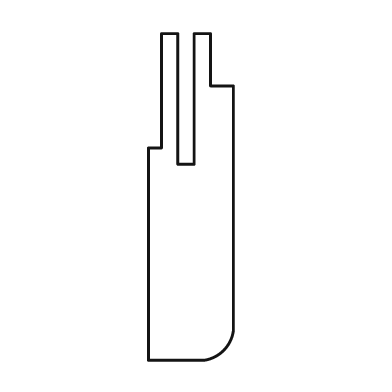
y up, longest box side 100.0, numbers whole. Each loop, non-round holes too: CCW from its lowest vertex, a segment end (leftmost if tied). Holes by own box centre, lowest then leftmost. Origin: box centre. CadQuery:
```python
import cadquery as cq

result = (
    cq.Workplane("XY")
    .moveTo(-13.0, -50.0)
    .lineTo(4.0, -50.0)
    .threePointArc((10.0, -47.0), (13.0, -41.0))
    .lineTo(13.0, 34.0)
    .lineTo(6.0, 34.0)
    .lineTo(6.0, 50.0)
    .lineTo(1.0, 50.0)
    .lineTo(1.0, 10.0)
    .lineTo(-4.0, 10.0)
    .lineTo(-4.0, 50.0)
    .lineTo(-9.0, 50.0)
    .lineTo(-9.0, 15.0)
    .lineTo(-13.0, 15.0)
    .close()
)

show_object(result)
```